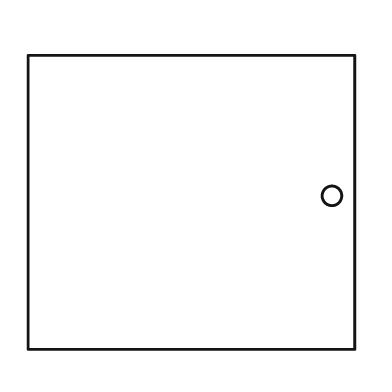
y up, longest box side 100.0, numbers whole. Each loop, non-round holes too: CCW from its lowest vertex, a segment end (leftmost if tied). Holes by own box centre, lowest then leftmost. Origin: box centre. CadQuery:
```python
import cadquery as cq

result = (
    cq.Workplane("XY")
    .moveTo(-50.0, -45.0)
    .lineTo(50.0, -45.0)
    .lineTo(50.0, 45.0)
    .lineTo(-50.0, 45.0)
    .close()
    .moveTo(43.0, 2.0)
    .circle(3.0)
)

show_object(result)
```